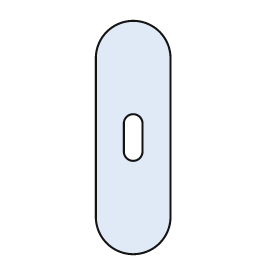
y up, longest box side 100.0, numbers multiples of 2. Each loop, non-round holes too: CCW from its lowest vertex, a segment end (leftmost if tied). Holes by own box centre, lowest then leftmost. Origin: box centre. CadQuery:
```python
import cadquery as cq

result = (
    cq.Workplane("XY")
    .moveTo(-16.0, -34.0)
    .threePointArc((0.0, -50.0), (16.0, -34.0))
    .lineTo(16.0, 34.0)
    .threePointArc((0.0, 50.0), (-16.0, 34.0))
    .close()
    .moveTo(-4.0, -6.0)
    .threePointArc((0.0, -10.0), (4.0, -6.0))
    .lineTo(4.0, 6.0)
    .threePointArc((0.0, 10.0), (-4.0, 6.0))
    .close()
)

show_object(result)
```